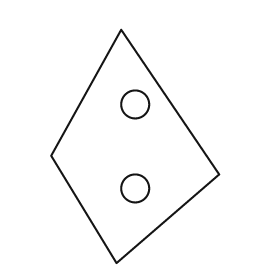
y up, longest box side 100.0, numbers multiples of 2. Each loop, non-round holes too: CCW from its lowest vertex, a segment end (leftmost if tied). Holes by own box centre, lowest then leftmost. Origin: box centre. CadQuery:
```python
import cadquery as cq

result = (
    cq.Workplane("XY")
    .moveTo(-8.0, -50.0)
    .lineTo(36.0, -12.0)
    .lineTo(-6.0, 50.0)
    .lineTo(-36.0, -4.0)
    .close()
    .moveTo(0.0, -18.0)
    .circle(6.0)
    .moveTo(0.0, 18.0)
    .circle(6.0)
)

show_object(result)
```